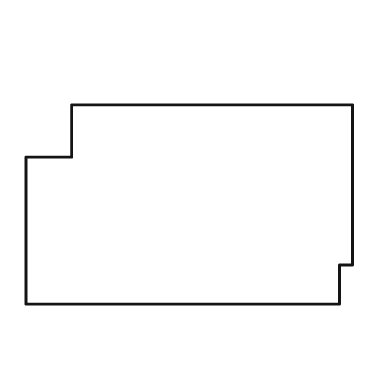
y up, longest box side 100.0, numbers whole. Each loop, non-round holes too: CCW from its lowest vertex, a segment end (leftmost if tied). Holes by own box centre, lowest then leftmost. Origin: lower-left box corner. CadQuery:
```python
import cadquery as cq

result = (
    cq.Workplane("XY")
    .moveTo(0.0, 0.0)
    .lineTo(96.0, 0.0)
    .lineTo(96.0, 12.0)
    .lineTo(100.0, 12.0)
    .lineTo(100.0, 61.0)
    .lineTo(14.0, 61.0)
    .lineTo(14.0, 45.0)
    .lineTo(0.0, 45.0)
    .close()
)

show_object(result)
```